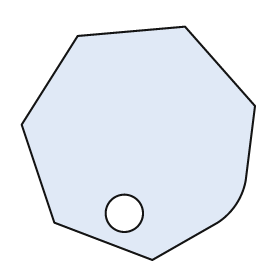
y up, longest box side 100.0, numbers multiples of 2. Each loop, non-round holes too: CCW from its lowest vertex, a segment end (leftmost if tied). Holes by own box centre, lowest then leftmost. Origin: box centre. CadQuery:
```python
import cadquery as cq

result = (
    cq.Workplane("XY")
    .moveTo(6.0, -50.0)
    .lineTo(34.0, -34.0)
    .threePointArc((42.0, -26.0), (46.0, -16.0))
    .lineTo(50.0, 16.0)
    .lineTo(20.0, 50.0)
    .lineTo(-26.0, 46.0)
    .lineTo(-50.0, 8.0)
    .lineTo(-36.0, -34.0)
    .close()
    .moveTo(-6.0, -30.0)
    .circle(8.0)
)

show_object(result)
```